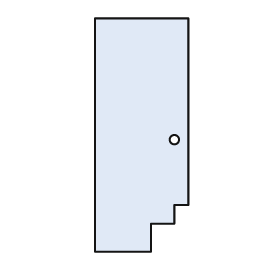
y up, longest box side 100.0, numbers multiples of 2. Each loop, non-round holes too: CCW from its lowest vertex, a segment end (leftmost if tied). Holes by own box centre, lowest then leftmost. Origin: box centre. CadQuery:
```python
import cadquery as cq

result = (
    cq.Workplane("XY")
    .moveTo(-20.0, -50.0)
    .lineTo(4.0, -50.0)
    .lineTo(4.0, -38.0)
    .lineTo(14.0, -38.0)
    .lineTo(14.0, -30.0)
    .lineTo(20.0, -30.0)
    .lineTo(20.0, 50.0)
    .lineTo(-20.0, 50.0)
    .close()
    .moveTo(14.0, -2.0)
    .circle(2.0)
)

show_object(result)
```